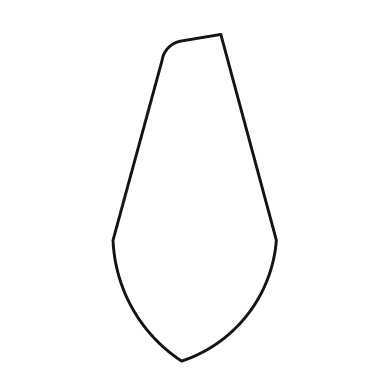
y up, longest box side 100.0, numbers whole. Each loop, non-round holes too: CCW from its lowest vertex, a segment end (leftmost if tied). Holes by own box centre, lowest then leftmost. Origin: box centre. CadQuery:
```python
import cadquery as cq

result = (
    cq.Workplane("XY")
    .moveTo(-4.0, -50.0)
    .threePointArc((16.0, -36.0), (25.0, -13.0))
    .lineTo(8.0, 50.0)
    .lineTo(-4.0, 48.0)
    .threePointArc((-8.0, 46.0), (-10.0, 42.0))
    .lineTo(-25.0, -13.0)
    .threePointArc((-19.0, -34.0), (-4.0, -50.0))
    .close()
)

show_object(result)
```